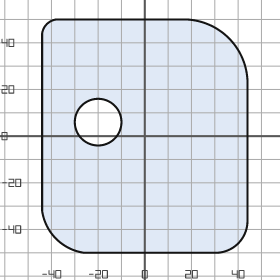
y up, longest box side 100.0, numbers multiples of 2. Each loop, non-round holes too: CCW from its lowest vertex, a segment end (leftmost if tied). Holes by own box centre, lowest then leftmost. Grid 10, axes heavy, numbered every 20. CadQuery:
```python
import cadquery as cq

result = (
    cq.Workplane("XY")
    .moveTo(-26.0, -50.0)
    .lineTo(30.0, -50.0)
    .threePointArc((40.0, -46.0), (44.0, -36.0))
    .lineTo(44.0, 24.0)
    .threePointArc((36.0, 42.0), (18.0, 50.0))
    .lineTo(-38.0, 50.0)
    .threePointArc((-42.0, 48.0), (-44.0, 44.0))
    .lineTo(-44.0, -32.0)
    .threePointArc((-38.0, -44.0), (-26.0, -50.0))
    .close()
    .moveTo(-20.0, 6.0)
    .circle(10.0)
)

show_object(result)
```